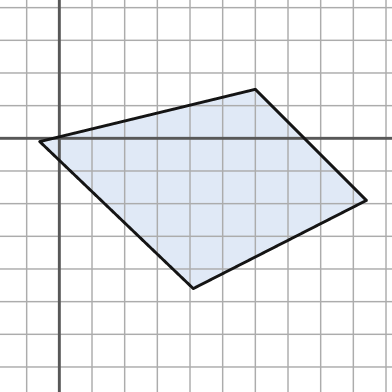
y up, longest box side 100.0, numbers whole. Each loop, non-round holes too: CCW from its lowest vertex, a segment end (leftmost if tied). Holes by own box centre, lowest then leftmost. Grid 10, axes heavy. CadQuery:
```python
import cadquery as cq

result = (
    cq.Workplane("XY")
    .moveTo(41.0, -46.0)
    .lineTo(94.0, -19.0)
    .lineTo(60.0, 15.0)
    .lineTo(-6.0, -1.0)
    .close()
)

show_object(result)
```